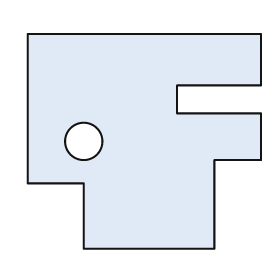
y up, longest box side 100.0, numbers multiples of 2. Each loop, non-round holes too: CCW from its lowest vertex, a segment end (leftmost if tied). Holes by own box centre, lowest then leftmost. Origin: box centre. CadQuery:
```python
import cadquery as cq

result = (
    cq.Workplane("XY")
    .moveTo(-26.0, -46.0)
    .lineTo(30.0, -46.0)
    .lineTo(30.0, -8.0)
    .lineTo(50.0, -8.0)
    .lineTo(50.0, 12.0)
    .lineTo(14.0, 12.0)
    .lineTo(14.0, 24.0)
    .lineTo(50.0, 24.0)
    .lineTo(50.0, 46.0)
    .lineTo(-50.0, 46.0)
    .lineTo(-50.0, -18.0)
    .lineTo(-26.0, -18.0)
    .close()
    .moveTo(-26.0, 0.0)
    .circle(8.0)
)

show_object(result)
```